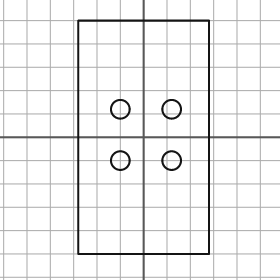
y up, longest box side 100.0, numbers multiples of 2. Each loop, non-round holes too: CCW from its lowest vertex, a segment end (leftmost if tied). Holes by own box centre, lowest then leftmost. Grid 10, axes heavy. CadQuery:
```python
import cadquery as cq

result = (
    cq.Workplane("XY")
    .moveTo(-28.0, -50.0)
    .lineTo(28.0, -50.0)
    .lineTo(28.0, 50.0)
    .lineTo(-28.0, 50.0)
    .close()
    .moveTo(-10.0, -10.0)
    .circle(4.0)
    .moveTo(12.0, -10.0)
    .circle(4.0)
    .moveTo(-10.0, 12.0)
    .circle(4.0)
    .moveTo(12.0, 12.0)
    .circle(4.0)
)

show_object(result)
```